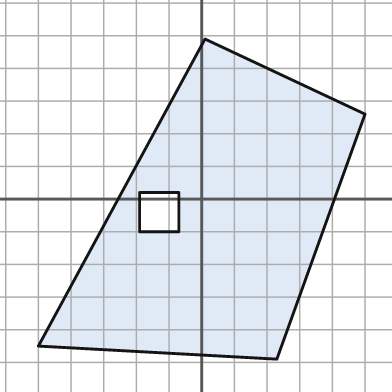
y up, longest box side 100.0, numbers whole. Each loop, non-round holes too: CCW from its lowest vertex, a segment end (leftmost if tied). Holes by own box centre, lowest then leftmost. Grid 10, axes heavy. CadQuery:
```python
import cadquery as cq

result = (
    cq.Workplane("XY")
    .moveTo(23.0, -49.0)
    .lineTo(50.0, 26.0)
    .lineTo(1.0, 49.0)
    .lineTo(-50.0, -45.0)
    .close()
    .moveTo(-19.0, -10.0)
    .lineTo(-7.0, -10.0)
    .lineTo(-7.0, 2.0)
    .lineTo(-19.0, 2.0)
    .close()
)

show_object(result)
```